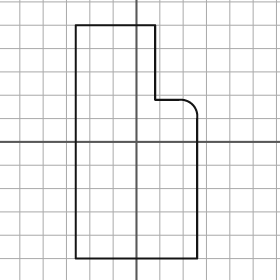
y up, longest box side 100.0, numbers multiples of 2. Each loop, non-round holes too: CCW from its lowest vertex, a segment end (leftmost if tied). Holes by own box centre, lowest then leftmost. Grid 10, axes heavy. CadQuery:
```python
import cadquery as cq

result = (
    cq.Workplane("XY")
    .moveTo(-26.0, -50.0)
    .lineTo(26.0, -50.0)
    .lineTo(26.0, 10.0)
    .threePointArc((24.0, 16.0), (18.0, 18.0))
    .lineTo(8.0, 18.0)
    .lineTo(8.0, 50.0)
    .lineTo(-26.0, 50.0)
    .close()
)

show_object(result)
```